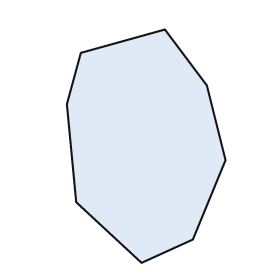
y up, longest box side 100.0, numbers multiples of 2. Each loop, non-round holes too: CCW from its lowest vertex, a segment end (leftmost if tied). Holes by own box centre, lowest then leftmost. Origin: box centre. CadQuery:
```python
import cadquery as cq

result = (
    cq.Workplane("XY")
    .moveTo(-2.0, -50.0)
    .lineTo(20.0, -40.0)
    .lineTo(34.0, -6.0)
    .lineTo(26.0, 26.0)
    .lineTo(8.0, 50.0)
    .lineTo(-28.0, 40.0)
    .lineTo(-34.0, 18.0)
    .lineTo(-30.0, -24.0)
    .close()
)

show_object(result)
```